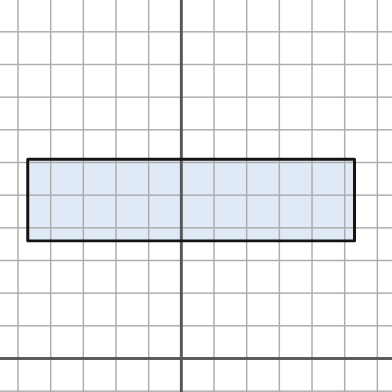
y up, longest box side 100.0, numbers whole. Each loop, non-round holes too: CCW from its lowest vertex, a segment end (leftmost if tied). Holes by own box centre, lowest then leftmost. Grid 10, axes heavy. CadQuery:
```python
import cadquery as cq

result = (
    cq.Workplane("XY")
    .moveTo(-47.0, 36.0)
    .lineTo(53.0, 36.0)
    .lineTo(53.0, 61.0)
    .lineTo(-47.0, 61.0)
    .close()
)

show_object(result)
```